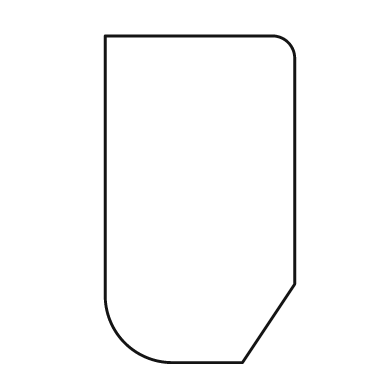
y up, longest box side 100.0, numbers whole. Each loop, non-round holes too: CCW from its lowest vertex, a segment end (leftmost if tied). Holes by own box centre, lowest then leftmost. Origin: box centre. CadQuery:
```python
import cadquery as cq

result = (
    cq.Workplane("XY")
    .moveTo(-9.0, -50.0)
    .lineTo(13.0, -50.0)
    .lineTo(29.0, -26.0)
    .lineTo(29.0, 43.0)
    .threePointArc((27.0, 48.0), (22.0, 50.0))
    .lineTo(-29.0, 50.0)
    .lineTo(-29.0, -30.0)
    .threePointArc((-23.0, -44.0), (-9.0, -50.0))
    .close()
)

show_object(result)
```